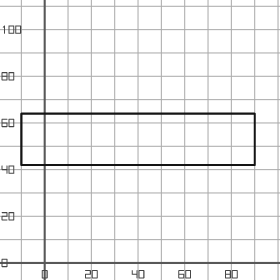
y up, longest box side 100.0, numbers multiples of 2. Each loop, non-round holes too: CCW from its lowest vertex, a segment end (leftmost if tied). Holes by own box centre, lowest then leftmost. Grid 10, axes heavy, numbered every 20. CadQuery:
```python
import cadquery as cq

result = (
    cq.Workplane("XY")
    .moveTo(-10.0, 42.0)
    .lineTo(90.0, 42.0)
    .lineTo(90.0, 64.0)
    .lineTo(-10.0, 64.0)
    .close()
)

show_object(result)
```